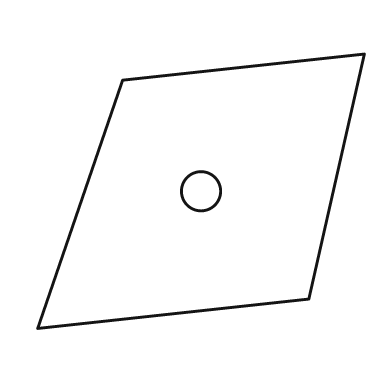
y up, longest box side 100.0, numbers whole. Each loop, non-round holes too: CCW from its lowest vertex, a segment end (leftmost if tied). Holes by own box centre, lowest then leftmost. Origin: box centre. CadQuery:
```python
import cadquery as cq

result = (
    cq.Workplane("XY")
    .moveTo(-50.0, -42.0)
    .lineTo(33.0, -33.0)
    .lineTo(50.0, 42.0)
    .lineTo(-24.0, 34.0)
    .close()
    .moveTo(0.0, 0.0)
    .circle(6.0)
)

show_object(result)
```